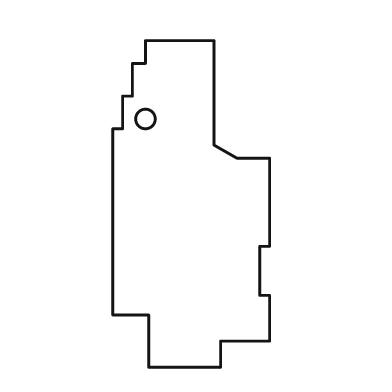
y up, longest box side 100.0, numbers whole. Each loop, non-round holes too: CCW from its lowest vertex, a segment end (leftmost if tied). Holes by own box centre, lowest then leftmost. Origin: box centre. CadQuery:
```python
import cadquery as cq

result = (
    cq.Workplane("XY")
    .moveTo(-13.0, -50.0)
    .lineTo(9.0, -50.0)
    .lineTo(9.0, -42.0)
    .lineTo(24.0, -42.0)
    .lineTo(24.0, -28.0)
    .lineTo(21.0, -28.0)
    .lineTo(21.0, -13.0)
    .lineTo(24.0, -13.0)
    .lineTo(24.0, 14.0)
    .lineTo(14.0, 14.0)
    .lineTo(7.0, 18.0)
    .lineTo(7.0, 50.0)
    .lineTo(-14.0, 50.0)
    .lineTo(-14.0, 43.0)
    .lineTo(-18.0, 43.0)
    .lineTo(-18.0, 33.0)
    .lineTo(-21.0, 33.0)
    .lineTo(-21.0, 23.0)
    .lineTo(-24.0, 23.0)
    .lineTo(-24.0, -34.0)
    .lineTo(-13.0, -34.0)
    .close()
    .moveTo(-14.0, 26.0)
    .circle(3.0)
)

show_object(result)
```